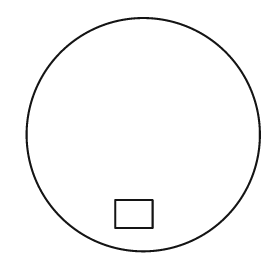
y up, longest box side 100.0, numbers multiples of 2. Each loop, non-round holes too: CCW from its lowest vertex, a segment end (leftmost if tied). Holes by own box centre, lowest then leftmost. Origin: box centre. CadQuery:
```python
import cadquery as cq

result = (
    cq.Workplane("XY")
    .moveTo(0.0, 0.0)
    .circle(50.0)
    .moveTo(-12.0, -40.0)
    .lineTo(4.0, -40.0)
    .lineTo(4.0, -28.0)
    .lineTo(-12.0, -28.0)
    .close()
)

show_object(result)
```